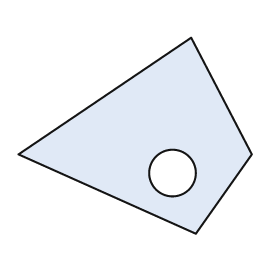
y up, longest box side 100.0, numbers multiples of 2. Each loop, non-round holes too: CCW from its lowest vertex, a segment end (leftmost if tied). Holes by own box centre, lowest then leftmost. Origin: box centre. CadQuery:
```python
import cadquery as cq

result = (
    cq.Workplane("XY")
    .moveTo(26.0, -42.0)
    .lineTo(50.0, -8.0)
    .lineTo(24.0, 42.0)
    .lineTo(-50.0, -8.0)
    .close()
    .moveTo(16.0, -16.0)
    .circle(10.0)
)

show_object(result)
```